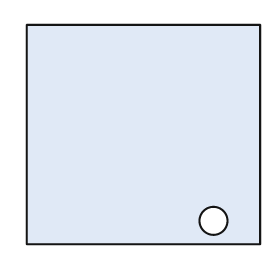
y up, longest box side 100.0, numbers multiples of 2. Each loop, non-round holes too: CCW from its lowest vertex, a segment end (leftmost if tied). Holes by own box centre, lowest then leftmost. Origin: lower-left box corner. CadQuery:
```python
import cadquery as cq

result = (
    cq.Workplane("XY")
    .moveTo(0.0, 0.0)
    .lineTo(100.0, 0.0)
    .lineTo(100.0, 94.0)
    .lineTo(0.0, 94.0)
    .close()
    .moveTo(80.0, 10.0)
    .circle(6.0)
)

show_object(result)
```